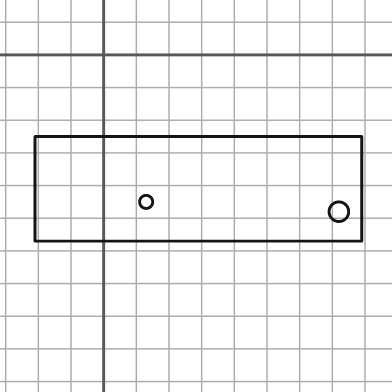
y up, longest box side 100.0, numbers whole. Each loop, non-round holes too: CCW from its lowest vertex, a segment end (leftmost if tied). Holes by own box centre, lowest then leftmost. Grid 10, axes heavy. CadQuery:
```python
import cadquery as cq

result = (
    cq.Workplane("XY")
    .moveTo(-21.0, -57.0)
    .lineTo(79.0, -57.0)
    .lineTo(79.0, -25.0)
    .lineTo(-21.0, -25.0)
    .close()
    .moveTo(72.0, -48.0)
    .circle(3.0)
    .moveTo(13.0, -45.0)
    .circle(2.0)
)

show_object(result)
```